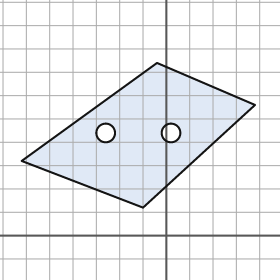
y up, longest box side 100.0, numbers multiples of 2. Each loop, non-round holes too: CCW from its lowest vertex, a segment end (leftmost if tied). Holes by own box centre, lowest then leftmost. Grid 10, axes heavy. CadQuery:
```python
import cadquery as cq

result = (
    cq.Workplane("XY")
    .moveTo(-10.0, 12.0)
    .lineTo(38.0, 56.0)
    .lineTo(-4.0, 74.0)
    .lineTo(-62.0, 32.0)
    .close()
    .moveTo(-26.0, 44.0)
    .circle(4.0)
    .moveTo(2.0, 44.0)
    .circle(4.0)
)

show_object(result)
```